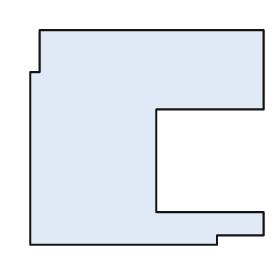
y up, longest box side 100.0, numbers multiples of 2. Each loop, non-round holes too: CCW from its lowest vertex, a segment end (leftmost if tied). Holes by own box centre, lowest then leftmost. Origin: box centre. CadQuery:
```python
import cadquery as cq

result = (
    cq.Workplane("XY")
    .moveTo(-50.0, -46.0)
    .lineTo(30.0, -46.0)
    .lineTo(30.0, -42.0)
    .lineTo(50.0, -42.0)
    .lineTo(50.0, -32.0)
    .lineTo(4.0, -32.0)
    .lineTo(4.0, 12.0)
    .lineTo(50.0, 12.0)
    .lineTo(50.0, 46.0)
    .lineTo(-46.0, 46.0)
    .lineTo(-46.0, 28.0)
    .lineTo(-50.0, 28.0)
    .close()
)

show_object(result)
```